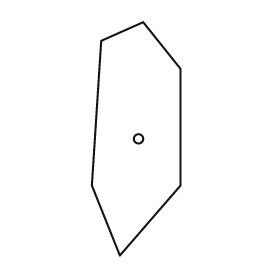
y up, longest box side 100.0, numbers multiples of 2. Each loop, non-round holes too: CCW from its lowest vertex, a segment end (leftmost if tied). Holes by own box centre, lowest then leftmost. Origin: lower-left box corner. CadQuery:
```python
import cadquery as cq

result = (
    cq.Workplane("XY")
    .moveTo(12.0, 0.0)
    .lineTo(38.0, 30.0)
    .lineTo(38.0, 80.0)
    .lineTo(22.0, 100.0)
    .lineTo(4.0, 92.0)
    .lineTo(0.0, 30.0)
    .close()
    .moveTo(20.0, 50.0)
    .circle(2.0)
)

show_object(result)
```